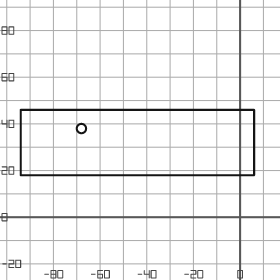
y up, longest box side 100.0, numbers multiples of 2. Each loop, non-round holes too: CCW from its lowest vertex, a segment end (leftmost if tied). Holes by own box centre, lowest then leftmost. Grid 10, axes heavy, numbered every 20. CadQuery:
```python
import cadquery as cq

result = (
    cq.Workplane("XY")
    .moveTo(-94.0, 18.0)
    .lineTo(6.0, 18.0)
    .lineTo(6.0, 46.0)
    .lineTo(-94.0, 46.0)
    .close()
    .moveTo(-68.0, 38.0)
    .circle(2.0)
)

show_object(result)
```